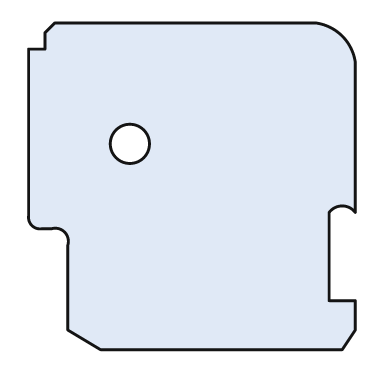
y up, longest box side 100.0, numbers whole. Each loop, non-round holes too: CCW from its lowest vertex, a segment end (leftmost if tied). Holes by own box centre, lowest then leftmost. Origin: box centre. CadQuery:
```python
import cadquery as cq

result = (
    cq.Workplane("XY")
    .moveTo(-28.0, -50.0)
    .lineTo(46.0, -50.0)
    .lineTo(50.0, -44.0)
    .lineTo(50.0, -35.0)
    .lineTo(42.0, -35.0)
    .lineTo(42.0, -8.0)
    .threePointArc((46.0, -6.0), (50.0, -8.0))
    .lineTo(50.0, 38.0)
    .threePointArc((46.0, 46.0), (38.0, 50.0))
    .lineTo(-42.0, 50.0)
    .lineTo(-45.0, 47.0)
    .lineTo(-45.0, 42.0)
    .lineTo(-50.0, 42.0)
    .lineTo(-50.0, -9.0)
    .threePointArc((-49.0, -12.0), (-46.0, -13.0))
    .lineTo(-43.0, -13.0)
    .threePointArc((-39.0, -14.0), (-38.0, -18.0))
    .lineTo(-38.0, -44.0)
    .close()
    .moveTo(-19.0, 13.0)
    .circle(6.0)
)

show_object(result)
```